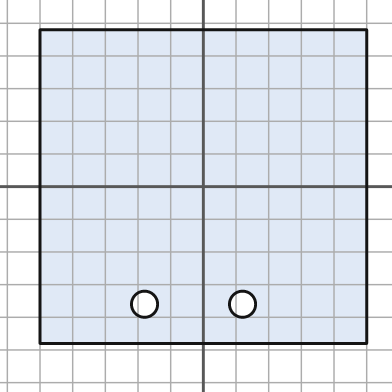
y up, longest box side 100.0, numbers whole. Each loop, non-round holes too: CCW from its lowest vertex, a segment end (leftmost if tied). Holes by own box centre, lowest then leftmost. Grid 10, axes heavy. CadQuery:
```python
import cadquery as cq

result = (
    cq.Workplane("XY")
    .moveTo(-50.0, -48.0)
    .lineTo(50.0, -48.0)
    .lineTo(50.0, 48.0)
    .lineTo(-50.0, 48.0)
    .close()
    .moveTo(-18.0, -36.0)
    .circle(4.0)
    .moveTo(12.0, -36.0)
    .circle(4.0)
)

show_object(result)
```